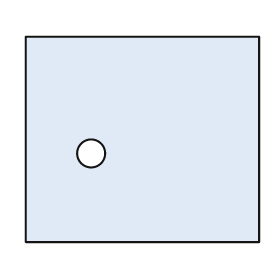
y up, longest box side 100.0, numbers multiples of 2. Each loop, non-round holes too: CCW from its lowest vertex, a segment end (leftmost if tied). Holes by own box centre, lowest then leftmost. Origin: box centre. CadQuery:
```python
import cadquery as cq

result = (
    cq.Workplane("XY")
    .moveTo(-50.0, -44.0)
    .lineTo(50.0, -44.0)
    .lineTo(50.0, 44.0)
    .lineTo(-50.0, 44.0)
    .close()
    .moveTo(-22.0, -6.0)
    .circle(6.0)
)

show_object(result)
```